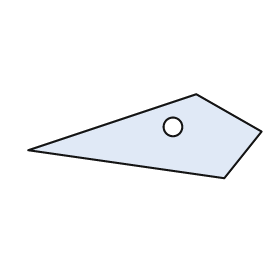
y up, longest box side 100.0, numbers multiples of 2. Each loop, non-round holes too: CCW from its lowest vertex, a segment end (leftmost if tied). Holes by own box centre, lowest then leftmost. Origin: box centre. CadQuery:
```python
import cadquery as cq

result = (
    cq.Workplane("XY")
    .moveTo(34.0, -18.0)
    .lineTo(50.0, 2.0)
    .lineTo(22.0, 18.0)
    .lineTo(-50.0, -6.0)
    .close()
    .moveTo(12.0, 4.0)
    .circle(4.0)
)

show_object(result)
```